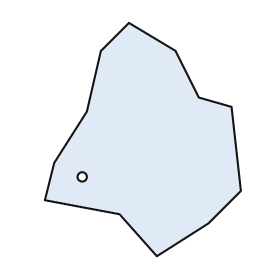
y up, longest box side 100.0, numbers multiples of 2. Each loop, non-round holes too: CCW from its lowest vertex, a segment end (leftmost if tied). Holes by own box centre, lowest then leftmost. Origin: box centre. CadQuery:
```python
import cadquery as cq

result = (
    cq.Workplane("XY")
    .moveTo(6.0, -50.0)
    .lineTo(28.0, -36.0)
    .lineTo(42.0, -22.0)
    .lineTo(38.0, 14.0)
    .lineTo(24.0, 18.0)
    .lineTo(14.0, 38.0)
    .lineTo(-6.0, 50.0)
    .lineTo(-18.0, 38.0)
    .lineTo(-24.0, 12.0)
    .lineTo(-38.0, -10.0)
    .lineTo(-42.0, -26.0)
    .lineTo(-10.0, -32.0)
    .close()
    .moveTo(-26.0, -16.0)
    .circle(2.0)
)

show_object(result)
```